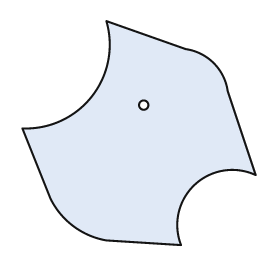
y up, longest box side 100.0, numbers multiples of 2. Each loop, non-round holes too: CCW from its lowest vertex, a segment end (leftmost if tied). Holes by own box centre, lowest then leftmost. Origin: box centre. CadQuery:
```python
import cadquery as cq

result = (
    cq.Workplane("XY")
    .moveTo(18.0, -48.0)
    .threePointArc((24.0, -22.0), (50.0, -18.0))
    .lineTo(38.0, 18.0)
    .threePointArc((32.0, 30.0), (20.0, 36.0))
    .lineTo(-14.0, 48.0)
    .threePointArc((-20.0, 16.0), (-50.0, 2.0))
    .lineTo(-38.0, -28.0)
    .threePointArc((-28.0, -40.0), (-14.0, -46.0))
    .close()
    .moveTo(2.0, 12.0)
    .circle(2.0)
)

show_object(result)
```